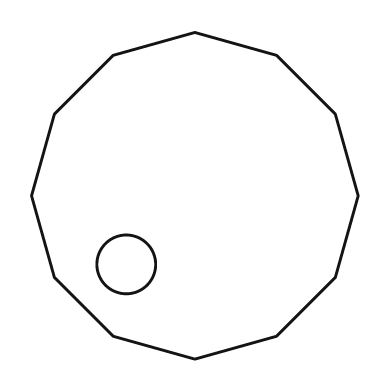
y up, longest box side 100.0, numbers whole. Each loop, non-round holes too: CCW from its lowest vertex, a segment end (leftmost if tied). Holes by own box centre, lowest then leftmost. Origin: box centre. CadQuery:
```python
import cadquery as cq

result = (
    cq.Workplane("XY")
    .moveTo(0.0, -50.0)
    .lineTo(25.0, -43.0)
    .lineTo(43.0, -25.0)
    .lineTo(50.0, 0.0)
    .lineTo(43.0, 25.0)
    .lineTo(25.0, 43.0)
    .lineTo(0.0, 50.0)
    .lineTo(-25.0, 43.0)
    .lineTo(-43.0, 25.0)
    .lineTo(-50.0, 0.0)
    .lineTo(-43.0, -25.0)
    .lineTo(-25.0, -43.0)
    .close()
    .moveTo(-21.0, -21.0)
    .circle(9.0)
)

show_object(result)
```